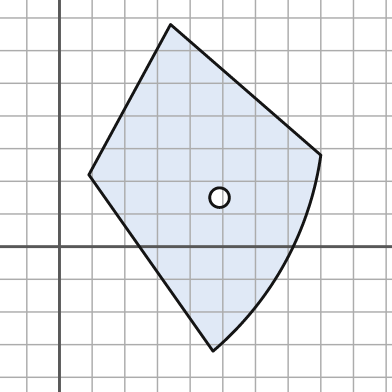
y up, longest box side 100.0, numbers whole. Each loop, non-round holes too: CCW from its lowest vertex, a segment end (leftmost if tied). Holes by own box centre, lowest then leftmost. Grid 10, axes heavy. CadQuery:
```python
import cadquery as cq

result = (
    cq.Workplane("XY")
    .moveTo(47.0, -32.0)
    .threePointArc((69.0, -5.0), (80.0, 28.0))
    .lineTo(34.0, 68.0)
    .lineTo(9.0, 22.0)
    .close()
    .moveTo(49.0, 15.0)
    .circle(3.0)
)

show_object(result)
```